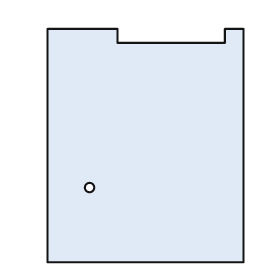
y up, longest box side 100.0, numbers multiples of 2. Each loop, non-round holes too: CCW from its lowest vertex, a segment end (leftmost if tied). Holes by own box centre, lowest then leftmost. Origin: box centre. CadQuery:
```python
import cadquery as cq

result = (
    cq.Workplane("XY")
    .moveTo(-42.0, -50.0)
    .lineTo(42.0, -50.0)
    .lineTo(42.0, 50.0)
    .lineTo(34.0, 50.0)
    .lineTo(34.0, 44.0)
    .lineTo(-12.0, 44.0)
    .lineTo(-12.0, 50.0)
    .lineTo(-42.0, 50.0)
    .close()
    .moveTo(-24.0, -18.0)
    .circle(2.0)
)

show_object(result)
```